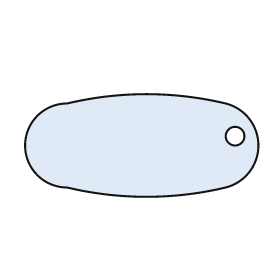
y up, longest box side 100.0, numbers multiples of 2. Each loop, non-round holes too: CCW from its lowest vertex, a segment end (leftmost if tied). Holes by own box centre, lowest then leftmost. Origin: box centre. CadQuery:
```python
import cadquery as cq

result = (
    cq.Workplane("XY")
    .moveTo(-32.0, -18.0)
    .threePointArc((2.0, -22.0), (36.0, -18.0))
    .threePointArc((50.0, 0.0), (36.0, 18.0))
    .threePointArc((2.0, 22.0), (-32.0, 18.0))
    .threePointArc((-50.0, 0.0), (-32.0, -18.0))
    .close()
    .moveTo(40.0, 4.0)
    .circle(4.0)
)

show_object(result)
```